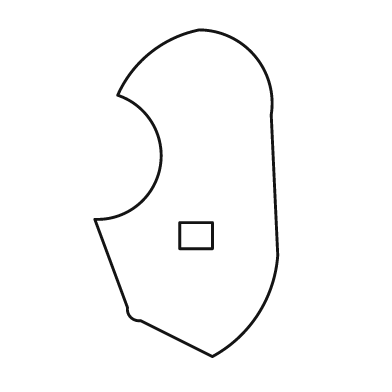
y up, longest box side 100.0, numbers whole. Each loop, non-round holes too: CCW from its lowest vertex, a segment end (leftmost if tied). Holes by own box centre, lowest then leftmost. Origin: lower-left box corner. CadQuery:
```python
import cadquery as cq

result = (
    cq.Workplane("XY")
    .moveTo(36.0, 0.0)
    .threePointArc((50.0, 13.0), (56.0, 31.0))
    .lineTo(54.0, 74.0)
    .threePointArc((49.0, 92.0), (32.0, 100.0))
    .threePointArc((17.0, 93.0), (7.0, 80.0))
    .threePointArc((20.0, 58.0), (0.0, 42.0))
    .lineTo(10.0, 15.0)
    .threePointArc((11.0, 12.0), (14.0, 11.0))
    .close()
    .moveTo(26.0, 33.0)
    .lineTo(36.0, 33.0)
    .lineTo(36.0, 41.0)
    .lineTo(26.0, 41.0)
    .close()
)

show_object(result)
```